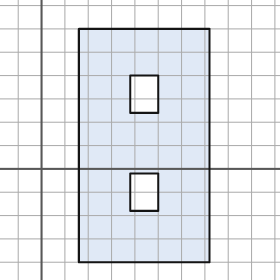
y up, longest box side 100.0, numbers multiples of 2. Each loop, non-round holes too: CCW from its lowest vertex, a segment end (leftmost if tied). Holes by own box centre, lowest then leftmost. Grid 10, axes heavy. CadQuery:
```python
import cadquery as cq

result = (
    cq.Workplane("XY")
    .moveTo(16.0, -40.0)
    .lineTo(72.0, -40.0)
    .lineTo(72.0, 60.0)
    .lineTo(16.0, 60.0)
    .close()
    .moveTo(38.0, -18.0)
    .lineTo(50.0, -18.0)
    .lineTo(50.0, -2.0)
    .lineTo(38.0, -2.0)
    .close()
    .moveTo(38.0, 24.0)
    .lineTo(50.0, 24.0)
    .lineTo(50.0, 40.0)
    .lineTo(38.0, 40.0)
    .close()
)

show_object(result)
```